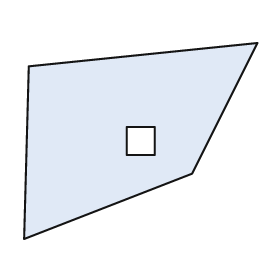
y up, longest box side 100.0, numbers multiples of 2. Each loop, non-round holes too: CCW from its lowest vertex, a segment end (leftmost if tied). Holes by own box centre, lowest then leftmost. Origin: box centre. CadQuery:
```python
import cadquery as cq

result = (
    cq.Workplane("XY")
    .moveTo(-50.0, -42.0)
    .lineTo(22.0, -14.0)
    .lineTo(50.0, 42.0)
    .lineTo(-48.0, 32.0)
    .close()
    .moveTo(-6.0, -6.0)
    .lineTo(6.0, -6.0)
    .lineTo(6.0, 6.0)
    .lineTo(-6.0, 6.0)
    .close()
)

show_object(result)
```